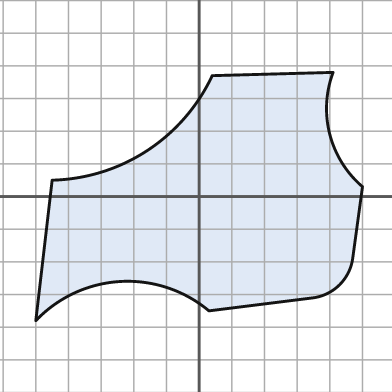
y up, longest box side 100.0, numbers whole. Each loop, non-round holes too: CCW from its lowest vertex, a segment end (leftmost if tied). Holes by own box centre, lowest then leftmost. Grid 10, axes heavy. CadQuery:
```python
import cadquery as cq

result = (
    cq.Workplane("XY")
    .moveTo(-50.0, -38.0)
    .threePointArc((-24.0, -26.0), (3.0, -35.0))
    .lineTo(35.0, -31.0)
    .threePointArc((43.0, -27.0), (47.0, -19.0))
    .lineTo(50.0, 3.0)
    .threePointArc((40.0, 19.0), (41.0, 38.0))
    .lineTo(4.0, 37.0)
    .threePointArc((-16.0, 14.0), (-45.0, 5.0))
    .close()
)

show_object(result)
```